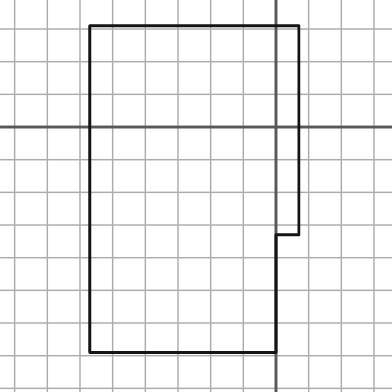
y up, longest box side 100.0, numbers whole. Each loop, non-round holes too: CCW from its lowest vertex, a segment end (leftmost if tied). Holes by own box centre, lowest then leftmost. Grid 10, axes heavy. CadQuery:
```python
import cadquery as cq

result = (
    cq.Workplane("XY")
    .moveTo(-57.0, -69.0)
    .lineTo(0.0, -69.0)
    .lineTo(0.0, -33.0)
    .lineTo(7.0, -33.0)
    .lineTo(7.0, 31.0)
    .lineTo(-57.0, 31.0)
    .close()
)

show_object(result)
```